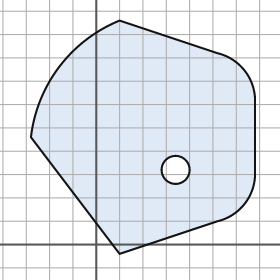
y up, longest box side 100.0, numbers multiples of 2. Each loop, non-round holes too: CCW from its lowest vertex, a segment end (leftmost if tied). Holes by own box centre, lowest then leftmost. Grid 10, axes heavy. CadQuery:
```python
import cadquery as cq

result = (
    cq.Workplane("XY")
    .moveTo(10.0, -4.0)
    .lineTo(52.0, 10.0)
    .threePointArc((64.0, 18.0), (68.0, 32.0))
    .lineTo(68.0, 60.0)
    .threePointArc((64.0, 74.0), (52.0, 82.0))
    .lineTo(10.0, 96.0)
    .threePointArc((-16.0, 76.0), (-28.0, 46.0))
    .close()
    .moveTo(34.0, 32.0)
    .circle(6.0)
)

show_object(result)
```